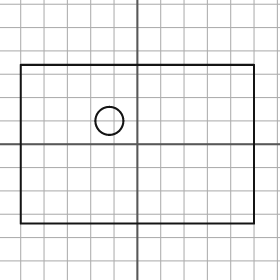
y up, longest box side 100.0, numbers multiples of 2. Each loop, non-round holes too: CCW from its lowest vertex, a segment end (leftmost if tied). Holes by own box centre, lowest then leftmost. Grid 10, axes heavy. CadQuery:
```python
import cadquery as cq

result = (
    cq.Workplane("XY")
    .moveTo(-50.0, -34.0)
    .lineTo(50.0, -34.0)
    .lineTo(50.0, 34.0)
    .lineTo(-50.0, 34.0)
    .close()
    .moveTo(-12.0, 10.0)
    .circle(6.0)
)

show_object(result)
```